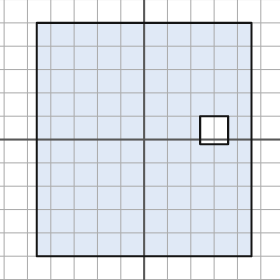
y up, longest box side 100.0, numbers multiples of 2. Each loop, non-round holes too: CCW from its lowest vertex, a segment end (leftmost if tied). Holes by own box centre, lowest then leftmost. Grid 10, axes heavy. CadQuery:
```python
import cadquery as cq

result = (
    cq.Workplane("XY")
    .moveTo(-46.0, -50.0)
    .lineTo(46.0, -50.0)
    .lineTo(46.0, 50.0)
    .lineTo(-46.0, 50.0)
    .close()
    .moveTo(24.0, -2.0)
    .lineTo(36.0, -2.0)
    .lineTo(36.0, 10.0)
    .lineTo(24.0, 10.0)
    .close()
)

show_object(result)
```